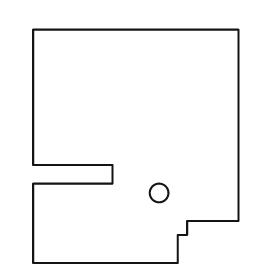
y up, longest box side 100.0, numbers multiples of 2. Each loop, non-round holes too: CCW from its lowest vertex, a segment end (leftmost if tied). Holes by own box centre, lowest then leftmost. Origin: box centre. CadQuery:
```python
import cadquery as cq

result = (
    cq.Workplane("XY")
    .moveTo(-44.0, -50.0)
    .lineTo(18.0, -50.0)
    .lineTo(18.0, -38.0)
    .lineTo(22.0, -38.0)
    .lineTo(22.0, -32.0)
    .lineTo(44.0, -32.0)
    .lineTo(44.0, 50.0)
    .lineTo(-44.0, 50.0)
    .lineTo(-44.0, -8.0)
    .lineTo(-10.0, -8.0)
    .lineTo(-10.0, -16.0)
    .lineTo(-44.0, -16.0)
    .close()
    .moveTo(10.0, -20.0)
    .circle(4.0)
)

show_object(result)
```